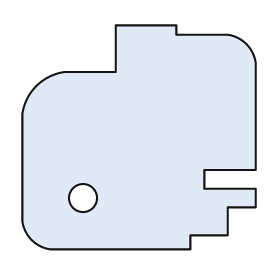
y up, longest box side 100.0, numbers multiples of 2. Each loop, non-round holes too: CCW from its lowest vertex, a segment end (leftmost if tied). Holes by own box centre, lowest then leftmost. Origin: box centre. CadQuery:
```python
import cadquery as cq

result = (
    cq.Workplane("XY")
    .moveTo(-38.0, -48.0)
    .lineTo(22.0, -48.0)
    .lineTo(22.0, -42.0)
    .lineTo(38.0, -42.0)
    .lineTo(38.0, -30.0)
    .lineTo(50.0, -30.0)
    .lineTo(50.0, -22.0)
    .lineTo(28.0, -22.0)
    .lineTo(28.0, -14.0)
    .lineTo(50.0, -14.0)
    .lineTo(50.0, 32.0)
    .threePointArc((46.0, 40.0), (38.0, 44.0))
    .lineTo(16.0, 44.0)
    .lineTo(16.0, 48.0)
    .lineTo(-10.0, 48.0)
    .lineTo(-10.0, 28.0)
    .lineTo(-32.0, 28.0)
    .threePointArc((-44.0, 22.0), (-50.0, 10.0))
    .lineTo(-50.0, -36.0)
    .threePointArc((-46.0, -44.0), (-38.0, -48.0))
    .close()
    .moveTo(-24.0, -26.0)
    .circle(6.0)
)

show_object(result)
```